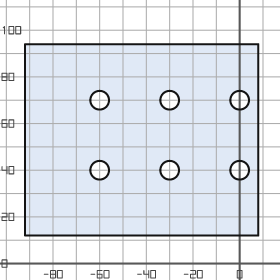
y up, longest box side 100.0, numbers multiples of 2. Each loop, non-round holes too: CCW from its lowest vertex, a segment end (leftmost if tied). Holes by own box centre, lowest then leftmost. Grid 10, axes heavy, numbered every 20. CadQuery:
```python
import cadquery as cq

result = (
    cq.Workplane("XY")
    .moveTo(-92.0, 12.0)
    .lineTo(8.0, 12.0)
    .lineTo(8.0, 94.0)
    .lineTo(-92.0, 94.0)
    .close()
    .moveTo(-60.0, 40.0)
    .circle(4.0)
    .moveTo(-30.0, 40.0)
    .circle(4.0)
    .moveTo(0.0, 40.0)
    .circle(4.0)
    .moveTo(-60.0, 70.0)
    .circle(4.0)
    .moveTo(-30.0, 70.0)
    .circle(4.0)
    .moveTo(0.0, 70.0)
    .circle(4.0)
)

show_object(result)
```